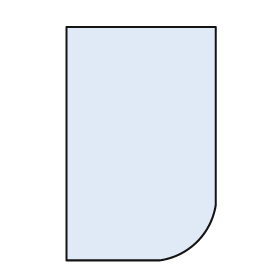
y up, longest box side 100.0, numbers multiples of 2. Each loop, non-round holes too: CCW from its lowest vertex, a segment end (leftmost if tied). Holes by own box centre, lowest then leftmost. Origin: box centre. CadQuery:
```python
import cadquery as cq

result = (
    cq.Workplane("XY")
    .moveTo(-32.0, -50.0)
    .lineTo(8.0, -50.0)
    .threePointArc((24.0, -42.0), (32.0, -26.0))
    .lineTo(32.0, 50.0)
    .lineTo(-32.0, 50.0)
    .close()
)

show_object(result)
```